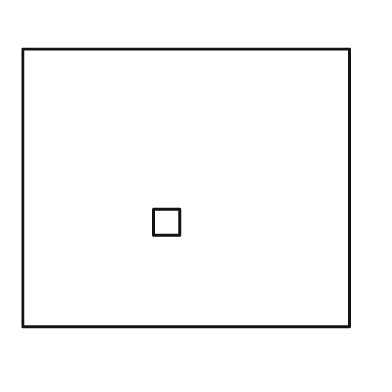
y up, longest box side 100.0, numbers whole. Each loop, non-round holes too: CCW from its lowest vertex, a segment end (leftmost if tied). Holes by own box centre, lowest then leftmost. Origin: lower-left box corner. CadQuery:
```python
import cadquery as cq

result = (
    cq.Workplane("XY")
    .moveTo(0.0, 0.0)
    .lineTo(100.0, 0.0)
    .lineTo(100.0, 85.0)
    .lineTo(0.0, 85.0)
    .close()
    .moveTo(40.0, 28.0)
    .lineTo(48.0, 28.0)
    .lineTo(48.0, 36.0)
    .lineTo(40.0, 36.0)
    .close()
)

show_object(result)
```